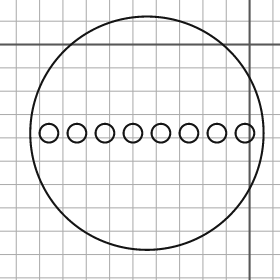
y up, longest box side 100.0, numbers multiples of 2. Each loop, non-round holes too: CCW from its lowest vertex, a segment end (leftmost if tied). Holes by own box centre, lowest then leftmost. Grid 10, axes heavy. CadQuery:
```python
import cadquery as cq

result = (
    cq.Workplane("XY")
    .moveTo(-44.0, -38.0)
    .circle(50.0)
    .moveTo(-86.0, -38.0)
    .circle(4.0)
    .moveTo(-74.0, -38.0)
    .circle(4.0)
    .moveTo(-62.0, -38.0)
    .circle(4.0)
    .moveTo(-50.0, -38.0)
    .circle(4.0)
    .moveTo(-38.0, -38.0)
    .circle(4.0)
    .moveTo(-26.0, -38.0)
    .circle(4.0)
    .moveTo(-14.0, -38.0)
    .circle(4.0)
    .moveTo(-2.0, -38.0)
    .circle(4.0)
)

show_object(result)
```